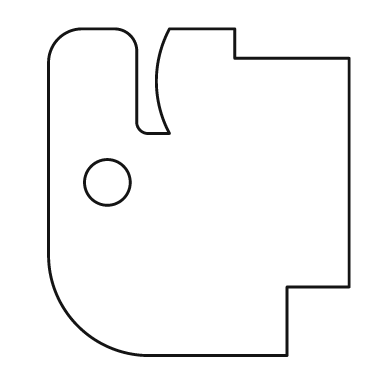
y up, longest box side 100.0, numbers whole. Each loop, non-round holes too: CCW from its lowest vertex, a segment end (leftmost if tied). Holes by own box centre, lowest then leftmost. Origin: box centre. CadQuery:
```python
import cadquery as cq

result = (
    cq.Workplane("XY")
    .moveTo(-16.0, -50.0)
    .lineTo(27.0, -50.0)
    .lineTo(27.0, -29.0)
    .lineTo(46.0, -29.0)
    .lineTo(46.0, 41.0)
    .lineTo(11.0, 41.0)
    .lineTo(11.0, 50.0)
    .lineTo(-9.0, 50.0)
    .threePointArc((-13.0, 34.0), (-9.0, 18.0))
    .lineTo(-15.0, 18.0)
    .threePointArc((-18.0, 19.0), (-19.0, 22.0))
    .lineTo(-19.0, 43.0)
    .threePointArc((-21.0, 48.0), (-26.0, 50.0))
    .lineTo(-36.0, 50.0)
    .threePointArc((-43.0, 47.0), (-46.0, 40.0))
    .lineTo(-46.0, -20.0)
    .threePointArc((-37.0, -41.0), (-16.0, -50.0))
    .close()
    .moveTo(-28.0, 3.0)
    .circle(7.0)
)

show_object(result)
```